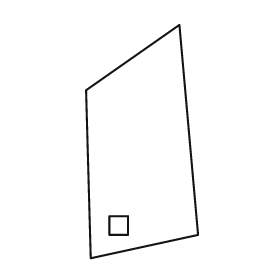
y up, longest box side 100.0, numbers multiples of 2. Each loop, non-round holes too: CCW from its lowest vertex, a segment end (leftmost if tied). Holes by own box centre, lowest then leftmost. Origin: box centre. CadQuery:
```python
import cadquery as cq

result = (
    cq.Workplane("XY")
    .moveTo(-22.0, -50.0)
    .lineTo(24.0, -40.0)
    .lineTo(16.0, 50.0)
    .lineTo(-24.0, 22.0)
    .close()
    .moveTo(-14.0, -40.0)
    .lineTo(-6.0, -40.0)
    .lineTo(-6.0, -32.0)
    .lineTo(-14.0, -32.0)
    .close()
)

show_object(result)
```